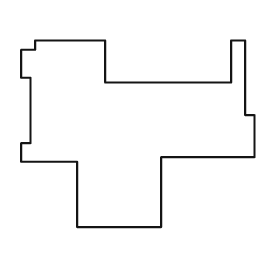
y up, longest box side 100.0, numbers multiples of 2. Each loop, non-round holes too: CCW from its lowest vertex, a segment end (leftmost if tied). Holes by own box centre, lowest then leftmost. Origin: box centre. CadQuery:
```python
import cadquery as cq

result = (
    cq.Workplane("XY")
    .moveTo(-26.0, -40.0)
    .lineTo(10.0, -40.0)
    .lineTo(10.0, -10.0)
    .lineTo(50.0, -10.0)
    .lineTo(50.0, 8.0)
    .lineTo(46.0, 8.0)
    .lineTo(46.0, 40.0)
    .lineTo(40.0, 40.0)
    .lineTo(40.0, 22.0)
    .lineTo(-14.0, 22.0)
    .lineTo(-14.0, 40.0)
    .lineTo(-44.0, 40.0)
    .lineTo(-44.0, 36.0)
    .lineTo(-50.0, 36.0)
    .lineTo(-50.0, 24.0)
    .lineTo(-46.0, 24.0)
    .lineTo(-46.0, -4.0)
    .lineTo(-50.0, -4.0)
    .lineTo(-50.0, -12.0)
    .lineTo(-26.0, -12.0)
    .close()
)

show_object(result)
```